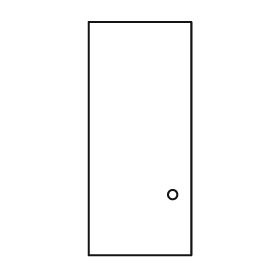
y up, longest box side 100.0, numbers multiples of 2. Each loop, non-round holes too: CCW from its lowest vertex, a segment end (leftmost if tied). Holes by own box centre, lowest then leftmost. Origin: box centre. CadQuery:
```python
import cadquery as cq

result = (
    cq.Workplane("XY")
    .moveTo(-22.0, -50.0)
    .lineTo(22.0, -50.0)
    .lineTo(22.0, 50.0)
    .lineTo(-22.0, 50.0)
    .close()
    .moveTo(14.0, -24.0)
    .circle(2.0)
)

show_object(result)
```